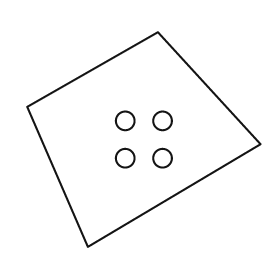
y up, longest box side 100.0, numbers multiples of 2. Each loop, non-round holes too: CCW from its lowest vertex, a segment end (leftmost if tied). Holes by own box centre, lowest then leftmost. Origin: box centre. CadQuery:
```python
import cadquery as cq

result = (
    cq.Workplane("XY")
    .moveTo(-24.0, -46.0)
    .lineTo(50.0, -2.0)
    .lineTo(6.0, 46.0)
    .lineTo(-50.0, 14.0)
    .close()
    .moveTo(-8.0, -8.0)
    .circle(4.0)
    .moveTo(8.0, -8.0)
    .circle(4.0)
    .moveTo(-8.0, 8.0)
    .circle(4.0)
    .moveTo(8.0, 8.0)
    .circle(4.0)
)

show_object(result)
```